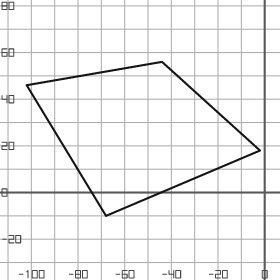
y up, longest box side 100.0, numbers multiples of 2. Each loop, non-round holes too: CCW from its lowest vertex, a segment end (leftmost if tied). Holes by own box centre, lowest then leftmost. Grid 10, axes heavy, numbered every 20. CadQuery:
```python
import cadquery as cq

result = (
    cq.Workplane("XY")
    .moveTo(-68.0, -10.0)
    .lineTo(-2.0, 18.0)
    .lineTo(-44.0, 56.0)
    .lineTo(-102.0, 46.0)
    .close()
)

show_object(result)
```